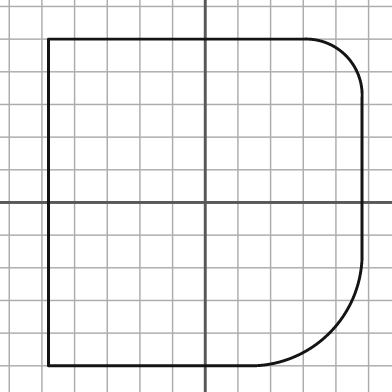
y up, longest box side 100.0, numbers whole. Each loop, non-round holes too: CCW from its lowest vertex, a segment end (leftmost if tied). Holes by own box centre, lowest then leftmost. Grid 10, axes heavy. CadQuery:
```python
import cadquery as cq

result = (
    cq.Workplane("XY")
    .moveTo(-48.0, -50.0)
    .lineTo(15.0, -50.0)
    .threePointArc((38.0, -40.0), (48.0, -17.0))
    .lineTo(48.0, 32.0)
    .threePointArc((43.0, 45.0), (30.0, 50.0))
    .lineTo(-48.0, 50.0)
    .close()
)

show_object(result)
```